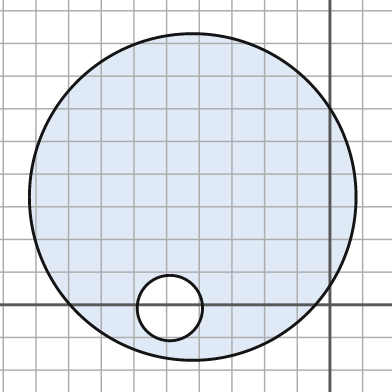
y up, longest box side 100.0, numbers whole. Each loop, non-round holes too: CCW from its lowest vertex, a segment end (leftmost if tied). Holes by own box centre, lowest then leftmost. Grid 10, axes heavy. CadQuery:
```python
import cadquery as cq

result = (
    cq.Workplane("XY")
    .moveTo(-42.0, 33.0)
    .circle(50.0)
    .moveTo(-49.0, -1.0)
    .circle(10.0)
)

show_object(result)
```